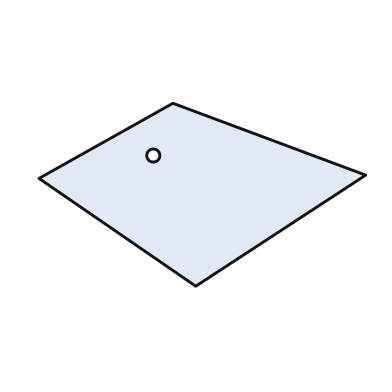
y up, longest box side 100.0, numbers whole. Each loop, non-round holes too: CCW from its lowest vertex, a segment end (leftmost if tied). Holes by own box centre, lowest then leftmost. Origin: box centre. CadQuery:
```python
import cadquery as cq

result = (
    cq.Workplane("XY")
    .moveTo(-2.0, -28.0)
    .lineTo(50.0, 6.0)
    .lineTo(-9.0, 28.0)
    .lineTo(-50.0, 5.0)
    .close()
    .moveTo(-15.0, 12.0)
    .circle(2.0)
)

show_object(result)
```